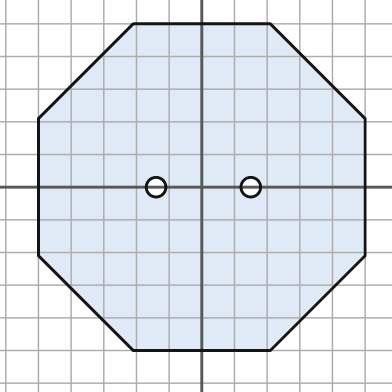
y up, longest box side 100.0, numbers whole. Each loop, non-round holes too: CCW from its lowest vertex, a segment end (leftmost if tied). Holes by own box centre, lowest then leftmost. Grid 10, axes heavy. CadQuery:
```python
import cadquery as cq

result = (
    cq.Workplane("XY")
    .moveTo(-21.0, -50.0)
    .lineTo(21.0, -50.0)
    .lineTo(50.0, -21.0)
    .lineTo(50.0, 21.0)
    .lineTo(21.0, 50.0)
    .lineTo(-21.0, 50.0)
    .lineTo(-50.0, 21.0)
    .lineTo(-50.0, -21.0)
    .close()
    .moveTo(-14.0, 0.0)
    .circle(3.0)
    .moveTo(15.0, 0.0)
    .circle(3.0)
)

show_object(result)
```